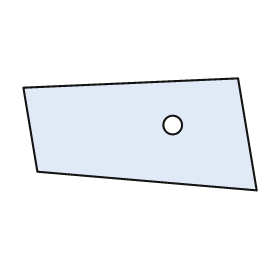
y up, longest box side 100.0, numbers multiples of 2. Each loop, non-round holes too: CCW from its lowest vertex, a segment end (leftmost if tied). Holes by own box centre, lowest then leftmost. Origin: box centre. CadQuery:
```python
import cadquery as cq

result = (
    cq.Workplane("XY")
    .moveTo(50.0, -24.0)
    .lineTo(42.0, 24.0)
    .lineTo(-50.0, 20.0)
    .lineTo(-44.0, -16.0)
    .close()
    .moveTo(14.0, 4.0)
    .circle(4.0)
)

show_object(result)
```